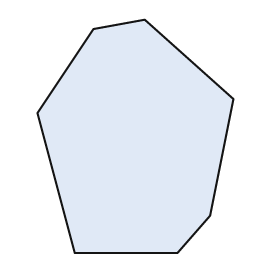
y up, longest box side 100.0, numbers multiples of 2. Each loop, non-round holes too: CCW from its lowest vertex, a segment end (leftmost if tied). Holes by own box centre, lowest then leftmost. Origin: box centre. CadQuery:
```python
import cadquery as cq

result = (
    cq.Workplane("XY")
    .moveTo(-26.0, -50.0)
    .lineTo(18.0, -50.0)
    .lineTo(32.0, -34.0)
    .lineTo(42.0, 16.0)
    .lineTo(4.0, 50.0)
    .lineTo(-18.0, 46.0)
    .lineTo(-42.0, 10.0)
    .close()
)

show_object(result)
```